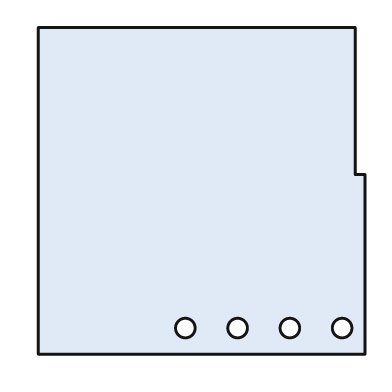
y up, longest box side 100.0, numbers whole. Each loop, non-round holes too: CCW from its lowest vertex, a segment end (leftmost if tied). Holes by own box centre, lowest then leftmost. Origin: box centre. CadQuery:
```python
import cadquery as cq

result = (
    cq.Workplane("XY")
    .moveTo(-50.0, -50.0)
    .lineTo(50.0, -50.0)
    .lineTo(50.0, 5.0)
    .lineTo(47.0, 5.0)
    .lineTo(47.0, 50.0)
    .lineTo(-50.0, 50.0)
    .close()
    .moveTo(-5.0, -42.0)
    .circle(3.0)
    .moveTo(11.0, -42.0)
    .circle(3.0)
    .moveTo(27.0, -42.0)
    .circle(3.0)
    .moveTo(43.0, -42.0)
    .circle(3.0)
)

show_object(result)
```